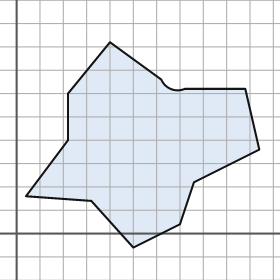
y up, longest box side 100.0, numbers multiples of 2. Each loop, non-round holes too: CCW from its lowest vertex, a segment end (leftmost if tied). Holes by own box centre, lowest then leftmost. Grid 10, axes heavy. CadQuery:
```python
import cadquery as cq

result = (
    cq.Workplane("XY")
    .moveTo(50.0, -6.0)
    .lineTo(70.0, 4.0)
    .lineTo(76.0, 22.0)
    .lineTo(104.0, 36.0)
    .lineTo(98.0, 62.0)
    .lineTo(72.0, 62.0)
    .threePointArc((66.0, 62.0), (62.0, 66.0))
    .lineTo(40.0, 82.0)
    .lineTo(22.0, 60.0)
    .lineTo(22.0, 40.0)
    .lineTo(4.0, 16.0)
    .lineTo(32.0, 14.0)
    .close()
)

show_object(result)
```